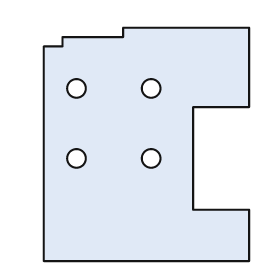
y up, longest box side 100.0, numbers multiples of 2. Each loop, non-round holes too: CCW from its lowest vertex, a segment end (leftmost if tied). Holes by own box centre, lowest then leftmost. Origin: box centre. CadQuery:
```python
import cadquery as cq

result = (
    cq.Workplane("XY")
    .moveTo(-44.0, -50.0)
    .lineTo(44.0, -50.0)
    .lineTo(44.0, -28.0)
    .lineTo(20.0, -28.0)
    .lineTo(20.0, 16.0)
    .lineTo(44.0, 16.0)
    .lineTo(44.0, 50.0)
    .lineTo(-10.0, 50.0)
    .lineTo(-10.0, 46.0)
    .lineTo(-36.0, 46.0)
    .lineTo(-36.0, 42.0)
    .lineTo(-44.0, 42.0)
    .close()
    .moveTo(-30.0, -6.0)
    .circle(4.0)
    .moveTo(2.0, -6.0)
    .circle(4.0)
    .moveTo(-30.0, 24.0)
    .circle(4.0)
    .moveTo(2.0, 24.0)
    .circle(4.0)
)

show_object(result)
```